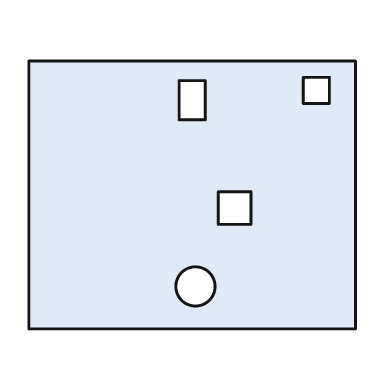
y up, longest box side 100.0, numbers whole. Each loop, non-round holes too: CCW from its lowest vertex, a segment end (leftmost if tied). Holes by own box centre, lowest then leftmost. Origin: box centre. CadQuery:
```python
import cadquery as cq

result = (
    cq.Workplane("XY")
    .moveTo(-50.0, -41.0)
    .lineTo(50.0, -41.0)
    .lineTo(50.0, 41.0)
    .lineTo(-50.0, 41.0)
    .close()
    .moveTo(1.0, -28.0)
    .circle(6.0)
    .moveTo(8.0, -9.0)
    .lineTo(18.0, -9.0)
    .lineTo(18.0, 1.0)
    .lineTo(8.0, 1.0)
    .close()
    .moveTo(-4.0, 23.0)
    .lineTo(4.0, 23.0)
    .lineTo(4.0, 35.0)
    .lineTo(-4.0, 35.0)
    .close()
    .moveTo(34.0, 28.0)
    .lineTo(42.0, 28.0)
    .lineTo(42.0, 36.0)
    .lineTo(34.0, 36.0)
    .close()
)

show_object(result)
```